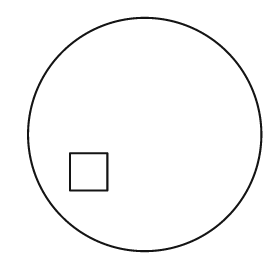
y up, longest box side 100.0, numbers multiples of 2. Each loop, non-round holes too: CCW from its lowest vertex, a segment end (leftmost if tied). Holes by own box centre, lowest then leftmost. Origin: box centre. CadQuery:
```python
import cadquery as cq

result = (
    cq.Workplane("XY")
    .moveTo(0.0, 0.0)
    .circle(50.0)
    .moveTo(-32.0, -24.0)
    .lineTo(-16.0, -24.0)
    .lineTo(-16.0, -8.0)
    .lineTo(-32.0, -8.0)
    .close()
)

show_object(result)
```